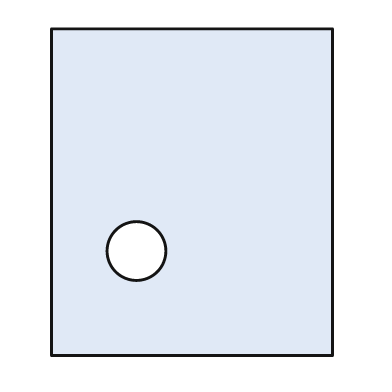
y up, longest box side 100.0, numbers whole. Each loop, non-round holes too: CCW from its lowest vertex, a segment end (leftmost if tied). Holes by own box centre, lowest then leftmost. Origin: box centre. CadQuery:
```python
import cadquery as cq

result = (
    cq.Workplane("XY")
    .moveTo(-43.0, -50.0)
    .lineTo(43.0, -50.0)
    .lineTo(43.0, 50.0)
    .lineTo(-43.0, 50.0)
    .close()
    .moveTo(-17.0, -18.0)
    .circle(9.0)
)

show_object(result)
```